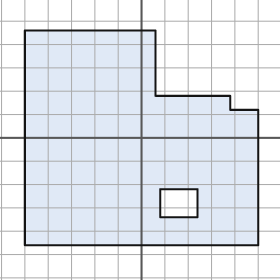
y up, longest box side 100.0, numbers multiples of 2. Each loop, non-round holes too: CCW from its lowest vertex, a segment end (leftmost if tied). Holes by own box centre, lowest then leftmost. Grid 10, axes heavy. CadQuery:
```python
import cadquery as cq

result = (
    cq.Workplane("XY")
    .moveTo(-50.0, -46.0)
    .lineTo(50.0, -46.0)
    .lineTo(50.0, 12.0)
    .lineTo(38.0, 12.0)
    .lineTo(38.0, 18.0)
    .lineTo(6.0, 18.0)
    .lineTo(6.0, 46.0)
    .lineTo(-50.0, 46.0)
    .close()
    .moveTo(8.0, -34.0)
    .lineTo(24.0, -34.0)
    .lineTo(24.0, -22.0)
    .lineTo(8.0, -22.0)
    .close()
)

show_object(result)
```